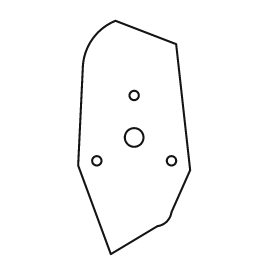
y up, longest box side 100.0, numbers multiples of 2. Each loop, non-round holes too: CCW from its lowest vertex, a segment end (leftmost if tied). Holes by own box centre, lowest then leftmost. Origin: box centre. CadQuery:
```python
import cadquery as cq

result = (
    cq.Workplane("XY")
    .moveTo(-10.0, -50.0)
    .lineTo(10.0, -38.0)
    .threePointArc((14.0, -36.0), (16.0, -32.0))
    .lineTo(24.0, -14.0)
    .lineTo(18.0, 40.0)
    .lineTo(-8.0, 50.0)
    .threePointArc((-18.0, 42.0), (-22.0, 30.0))
    .lineTo(-24.0, -12.0)
    .close()
    .moveTo(-16.0, -10.0)
    .circle(2.0)
    .moveTo(16.0, -10.0)
    .circle(2.0)
    .moveTo(0.0, 0.0)
    .circle(4.0)
    .moveTo(0.0, 18.0)
    .circle(2.0)
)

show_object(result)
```